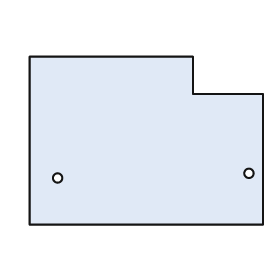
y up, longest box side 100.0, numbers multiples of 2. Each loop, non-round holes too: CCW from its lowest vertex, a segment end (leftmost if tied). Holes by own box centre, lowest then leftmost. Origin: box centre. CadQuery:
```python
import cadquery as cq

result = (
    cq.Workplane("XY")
    .moveTo(-50.0, -36.0)
    .lineTo(50.0, -36.0)
    .lineTo(50.0, 20.0)
    .lineTo(20.0, 20.0)
    .lineTo(20.0, 36.0)
    .lineTo(-50.0, 36.0)
    .close()
    .moveTo(-38.0, -16.0)
    .circle(2.0)
    .moveTo(44.0, -14.0)
    .circle(2.0)
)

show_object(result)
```